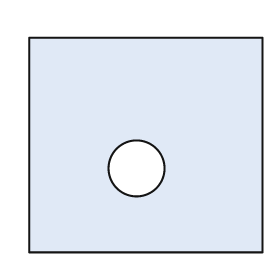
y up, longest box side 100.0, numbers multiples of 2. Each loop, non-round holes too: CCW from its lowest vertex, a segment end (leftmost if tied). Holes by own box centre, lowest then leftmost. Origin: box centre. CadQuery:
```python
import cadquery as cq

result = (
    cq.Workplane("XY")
    .moveTo(-50.0, -46.0)
    .lineTo(50.0, -46.0)
    .lineTo(50.0, 46.0)
    .lineTo(-50.0, 46.0)
    .close()
    .moveTo(-4.0, -10.0)
    .circle(12.0)
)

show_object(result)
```